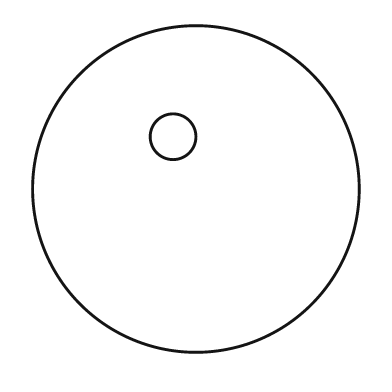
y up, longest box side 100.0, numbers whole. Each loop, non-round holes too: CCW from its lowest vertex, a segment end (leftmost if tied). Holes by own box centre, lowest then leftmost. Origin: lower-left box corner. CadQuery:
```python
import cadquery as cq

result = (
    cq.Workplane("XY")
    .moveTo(50.0, 50.0)
    .circle(50.0)
    .moveTo(43.0, 66.0)
    .circle(7.0)
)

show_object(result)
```